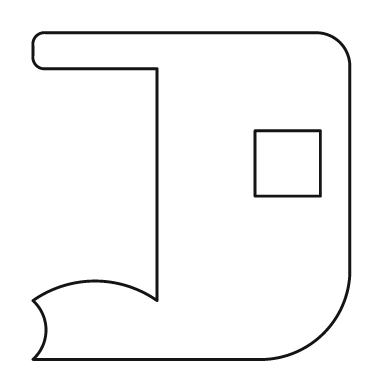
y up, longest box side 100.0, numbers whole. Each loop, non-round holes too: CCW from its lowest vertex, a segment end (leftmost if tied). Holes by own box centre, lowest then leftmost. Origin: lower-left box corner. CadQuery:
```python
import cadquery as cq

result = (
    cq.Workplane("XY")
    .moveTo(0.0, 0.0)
    .lineTo(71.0, 0.0)
    .threePointArc((89.0, 8.0), (97.0, 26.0))
    .lineTo(97.0, 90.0)
    .threePointArc((94.0, 97.0), (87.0, 100.0))
    .lineTo(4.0, 100.0)
    .threePointArc((1.0, 99.0), (0.0, 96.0))
    .lineTo(0.0, 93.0)
    .threePointArc((1.0, 90.0), (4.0, 89.0))
    .lineTo(38.0, 89.0)
    .lineTo(38.0, 18.0)
    .threePointArc((19.0, 24.0), (0.0, 18.0))
    .threePointArc((4.0, 9.0), (0.0, 0.0))
    .close()
    .moveTo(68.0, 50.0)
    .lineTo(88.0, 50.0)
    .lineTo(88.0, 70.0)
    .lineTo(68.0, 70.0)
    .close()
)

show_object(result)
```